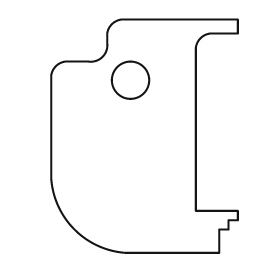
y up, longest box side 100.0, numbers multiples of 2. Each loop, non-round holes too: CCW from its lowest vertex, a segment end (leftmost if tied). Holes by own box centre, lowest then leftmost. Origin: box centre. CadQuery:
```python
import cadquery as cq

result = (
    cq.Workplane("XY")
    .moveTo(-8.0, -50.0)
    .lineTo(32.0, -50.0)
    .lineTo(32.0, -40.0)
    .lineTo(36.0, -40.0)
    .lineTo(36.0, -36.0)
    .lineTo(40.0, -36.0)
    .lineTo(40.0, -32.0)
    .lineTo(22.0, -32.0)
    .lineTo(22.0, 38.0)
    .threePointArc((24.0, 42.0), (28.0, 44.0))
    .lineTo(40.0, 44.0)
    .lineTo(40.0, 50.0)
    .lineTo(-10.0, 50.0)
    .threePointArc((-14.0, 48.0), (-16.0, 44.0))
    .lineTo(-16.0, 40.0)
    .threePointArc((-18.0, 34.0), (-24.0, 32.0))
    .lineTo(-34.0, 32.0)
    .threePointArc((-38.0, 30.0), (-40.0, 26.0))
    .lineTo(-40.0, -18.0)
    .threePointArc((-30.0, -40.0), (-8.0, -50.0))
    .close()
    .moveTo(-6.0, 24.0)
    .circle(8.0)
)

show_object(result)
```